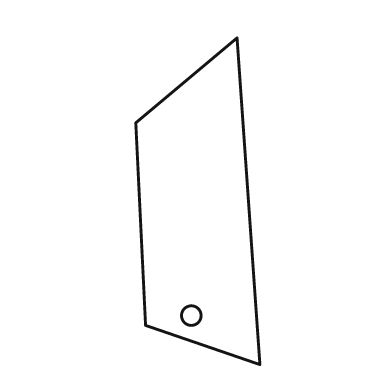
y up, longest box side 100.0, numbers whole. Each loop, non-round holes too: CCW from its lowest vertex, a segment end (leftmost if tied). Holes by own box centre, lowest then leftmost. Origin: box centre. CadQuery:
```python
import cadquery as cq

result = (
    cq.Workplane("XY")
    .moveTo(19.0, -50.0)
    .lineTo(12.0, 50.0)
    .lineTo(-19.0, 24.0)
    .lineTo(-16.0, -38.0)
    .close()
    .moveTo(-2.0, -35.0)
    .circle(3.0)
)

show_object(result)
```